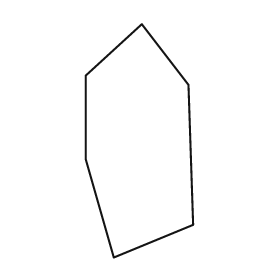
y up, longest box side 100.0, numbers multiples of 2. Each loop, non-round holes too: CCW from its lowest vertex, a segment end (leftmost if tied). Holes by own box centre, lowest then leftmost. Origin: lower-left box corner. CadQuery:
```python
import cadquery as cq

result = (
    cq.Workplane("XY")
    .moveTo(12.0, 0.0)
    .lineTo(46.0, 14.0)
    .lineTo(44.0, 74.0)
    .lineTo(24.0, 100.0)
    .lineTo(0.0, 78.0)
    .lineTo(0.0, 42.0)
    .close()
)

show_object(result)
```